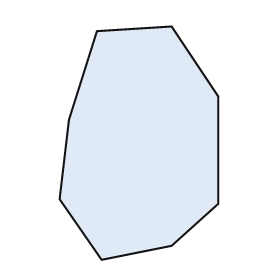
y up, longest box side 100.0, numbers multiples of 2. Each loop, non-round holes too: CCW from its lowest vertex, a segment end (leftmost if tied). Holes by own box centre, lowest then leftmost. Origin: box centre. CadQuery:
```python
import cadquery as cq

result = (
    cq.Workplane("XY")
    .moveTo(-16.0, -50.0)
    .lineTo(14.0, -44.0)
    .lineTo(34.0, -26.0)
    .lineTo(34.0, 20.0)
    .lineTo(14.0, 50.0)
    .lineTo(-18.0, 48.0)
    .lineTo(-30.0, 10.0)
    .lineTo(-34.0, -24.0)
    .close()
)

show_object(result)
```